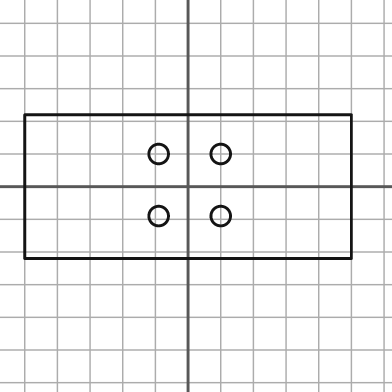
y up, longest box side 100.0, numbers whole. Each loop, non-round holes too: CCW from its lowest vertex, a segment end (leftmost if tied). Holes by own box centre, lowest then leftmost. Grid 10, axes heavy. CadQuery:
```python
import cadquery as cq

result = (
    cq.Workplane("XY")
    .moveTo(-50.0, -22.0)
    .lineTo(50.0, -22.0)
    .lineTo(50.0, 22.0)
    .lineTo(-50.0, 22.0)
    .close()
    .moveTo(-9.0, -9.0)
    .circle(3.0)
    .moveTo(10.0, -9.0)
    .circle(3.0)
    .moveTo(-9.0, 10.0)
    .circle(3.0)
    .moveTo(10.0, 10.0)
    .circle(3.0)
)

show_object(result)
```